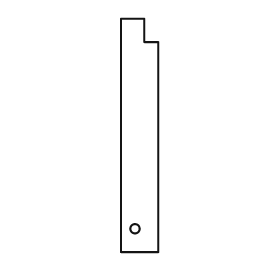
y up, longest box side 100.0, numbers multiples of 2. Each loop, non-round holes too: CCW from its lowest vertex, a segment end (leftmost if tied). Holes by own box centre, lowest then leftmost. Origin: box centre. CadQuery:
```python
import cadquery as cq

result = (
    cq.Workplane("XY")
    .moveTo(-8.0, -50.0)
    .lineTo(8.0, -50.0)
    .lineTo(8.0, 40.0)
    .lineTo(2.0, 40.0)
    .lineTo(2.0, 50.0)
    .lineTo(-8.0, 50.0)
    .close()
    .moveTo(-2.0, -40.0)
    .circle(2.0)
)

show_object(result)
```